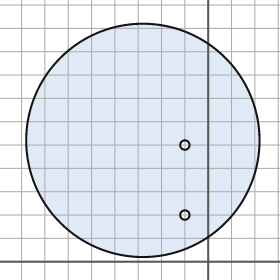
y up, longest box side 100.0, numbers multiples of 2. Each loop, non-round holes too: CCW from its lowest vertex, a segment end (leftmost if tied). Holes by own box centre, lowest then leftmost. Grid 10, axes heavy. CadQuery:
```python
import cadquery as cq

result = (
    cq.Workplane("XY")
    .moveTo(-28.0, 52.0)
    .circle(50.0)
    .moveTo(-10.0, 20.0)
    .circle(2.0)
    .moveTo(-10.0, 50.0)
    .circle(2.0)
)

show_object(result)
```